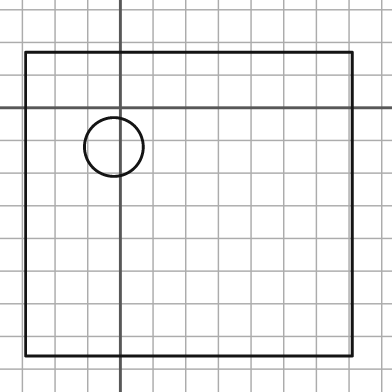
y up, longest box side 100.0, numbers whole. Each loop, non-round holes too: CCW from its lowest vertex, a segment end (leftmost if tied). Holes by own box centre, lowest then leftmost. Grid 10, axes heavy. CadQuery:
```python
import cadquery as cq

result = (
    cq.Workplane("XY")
    .moveTo(-29.0, -76.0)
    .lineTo(71.0, -76.0)
    .lineTo(71.0, 17.0)
    .lineTo(-29.0, 17.0)
    .close()
    .moveTo(-2.0, -12.0)
    .circle(9.0)
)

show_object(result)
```